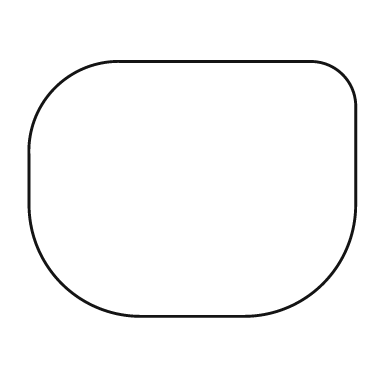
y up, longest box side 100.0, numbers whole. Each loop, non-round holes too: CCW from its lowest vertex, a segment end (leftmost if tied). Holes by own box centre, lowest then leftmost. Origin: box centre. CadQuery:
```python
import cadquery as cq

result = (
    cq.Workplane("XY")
    .moveTo(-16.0, -39.0)
    .lineTo(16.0, -39.0)
    .threePointArc((40.0, -29.0), (50.0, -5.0))
    .lineTo(50.0, 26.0)
    .threePointArc((46.0, 35.0), (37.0, 39.0))
    .lineTo(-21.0, 39.0)
    .threePointArc((-42.0, 31.0), (-50.0, 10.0))
    .lineTo(-50.0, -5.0)
    .threePointArc((-40.0, -29.0), (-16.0, -39.0))
    .close()
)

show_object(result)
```